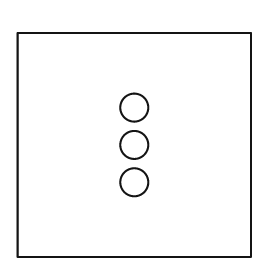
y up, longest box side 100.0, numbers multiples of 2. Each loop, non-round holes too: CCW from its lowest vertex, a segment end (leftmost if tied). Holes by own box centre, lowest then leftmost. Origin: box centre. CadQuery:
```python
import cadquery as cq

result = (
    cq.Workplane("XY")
    .moveTo(-50.0, -48.0)
    .lineTo(50.0, -48.0)
    .lineTo(50.0, 48.0)
    .lineTo(-50.0, 48.0)
    .close()
    .moveTo(0.0, -16.0)
    .circle(6.0)
    .moveTo(0.0, 0.0)
    .circle(6.0)
    .moveTo(0.0, 16.0)
    .circle(6.0)
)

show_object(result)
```